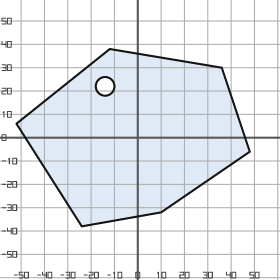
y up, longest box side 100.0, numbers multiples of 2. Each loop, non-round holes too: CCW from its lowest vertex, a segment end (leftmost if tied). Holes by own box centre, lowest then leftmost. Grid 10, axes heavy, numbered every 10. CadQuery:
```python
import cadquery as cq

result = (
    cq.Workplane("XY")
    .moveTo(-24.0, -38.0)
    .lineTo(10.0, -32.0)
    .lineTo(48.0, -6.0)
    .lineTo(36.0, 30.0)
    .lineTo(-12.0, 38.0)
    .lineTo(-52.0, 6.0)
    .close()
    .moveTo(-14.0, 22.0)
    .circle(4.0)
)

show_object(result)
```